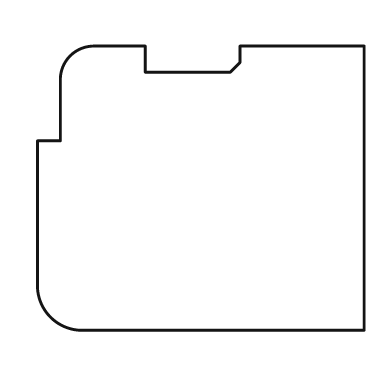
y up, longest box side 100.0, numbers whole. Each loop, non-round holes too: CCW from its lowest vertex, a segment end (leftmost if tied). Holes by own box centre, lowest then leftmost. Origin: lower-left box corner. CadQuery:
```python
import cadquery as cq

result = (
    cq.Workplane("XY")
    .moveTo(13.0, 0.0)
    .lineTo(100.0, 0.0)
    .lineTo(100.0, 87.0)
    .lineTo(62.0, 87.0)
    .lineTo(62.0, 82.0)
    .lineTo(59.0, 79.0)
    .lineTo(33.0, 79.0)
    .lineTo(33.0, 87.0)
    .lineTo(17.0, 87.0)
    .threePointArc((10.0, 84.0), (7.0, 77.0))
    .lineTo(7.0, 58.0)
    .lineTo(0.0, 58.0)
    .lineTo(0.0, 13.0)
    .threePointArc((4.0, 4.0), (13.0, 0.0))
    .close()
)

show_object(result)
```